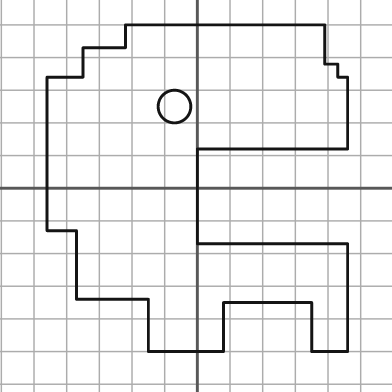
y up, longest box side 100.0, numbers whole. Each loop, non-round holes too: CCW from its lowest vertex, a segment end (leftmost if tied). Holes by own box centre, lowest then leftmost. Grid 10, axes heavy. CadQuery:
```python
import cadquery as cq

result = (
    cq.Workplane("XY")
    .moveTo(-15.0, -50.0)
    .lineTo(8.0, -50.0)
    .lineTo(8.0, -35.0)
    .lineTo(35.0, -35.0)
    .lineTo(35.0, -50.0)
    .lineTo(46.0, -50.0)
    .lineTo(46.0, -17.0)
    .lineTo(0.0, -17.0)
    .lineTo(0.0, 12.0)
    .lineTo(46.0, 12.0)
    .lineTo(46.0, 34.0)
    .lineTo(43.0, 34.0)
    .lineTo(43.0, 38.0)
    .lineTo(39.0, 38.0)
    .lineTo(39.0, 50.0)
    .lineTo(-22.0, 50.0)
    .lineTo(-22.0, 43.0)
    .lineTo(-35.0, 43.0)
    .lineTo(-35.0, 34.0)
    .lineTo(-46.0, 34.0)
    .lineTo(-46.0, -13.0)
    .lineTo(-37.0, -13.0)
    .lineTo(-37.0, -34.0)
    .lineTo(-15.0, -34.0)
    .close()
    .moveTo(-7.0, 25.0)
    .circle(5.0)
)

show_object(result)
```